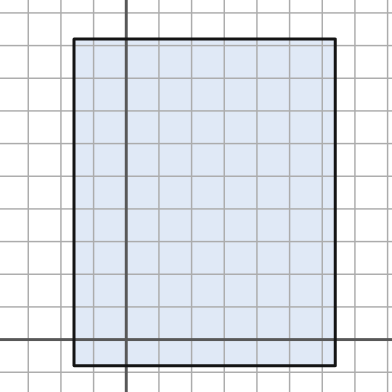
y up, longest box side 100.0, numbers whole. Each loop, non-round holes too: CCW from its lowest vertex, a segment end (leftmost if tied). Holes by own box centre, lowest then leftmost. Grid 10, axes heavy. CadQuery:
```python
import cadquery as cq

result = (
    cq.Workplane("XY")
    .moveTo(-16.0, -8.0)
    .lineTo(64.0, -8.0)
    .lineTo(64.0, 92.0)
    .lineTo(-16.0, 92.0)
    .close()
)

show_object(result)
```